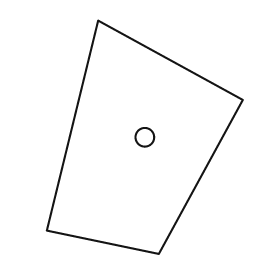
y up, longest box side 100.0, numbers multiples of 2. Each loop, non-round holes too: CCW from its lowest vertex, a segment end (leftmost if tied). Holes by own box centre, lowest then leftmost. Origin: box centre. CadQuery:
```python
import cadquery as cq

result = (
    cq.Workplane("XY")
    .moveTo(6.0, -50.0)
    .lineTo(42.0, 16.0)
    .lineTo(-20.0, 50.0)
    .lineTo(-42.0, -40.0)
    .close()
    .moveTo(0.0, 0.0)
    .circle(4.0)
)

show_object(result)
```